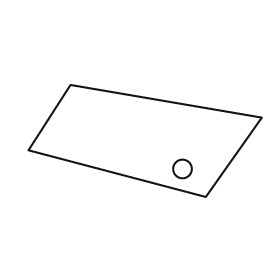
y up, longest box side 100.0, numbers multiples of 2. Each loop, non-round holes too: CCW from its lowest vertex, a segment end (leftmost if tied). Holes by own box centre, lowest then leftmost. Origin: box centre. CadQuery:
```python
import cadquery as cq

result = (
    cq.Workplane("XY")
    .moveTo(26.0, -24.0)
    .lineTo(50.0, 10.0)
    .lineTo(-32.0, 24.0)
    .lineTo(-50.0, -4.0)
    .close()
    .moveTo(16.0, -12.0)
    .circle(4.0)
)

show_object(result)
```